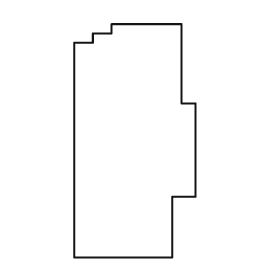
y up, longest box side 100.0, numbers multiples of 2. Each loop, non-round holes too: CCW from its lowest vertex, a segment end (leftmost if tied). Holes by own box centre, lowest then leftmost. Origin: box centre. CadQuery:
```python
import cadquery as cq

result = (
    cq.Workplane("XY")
    .moveTo(-26.0, -50.0)
    .lineTo(16.0, -50.0)
    .lineTo(16.0, -24.0)
    .lineTo(26.0, -24.0)
    .lineTo(26.0, 16.0)
    .lineTo(20.0, 16.0)
    .lineTo(20.0, 50.0)
    .lineTo(-10.0, 50.0)
    .lineTo(-10.0, 46.0)
    .lineTo(-18.0, 46.0)
    .lineTo(-18.0, 42.0)
    .lineTo(-26.0, 42.0)
    .close()
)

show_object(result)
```